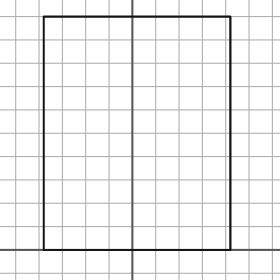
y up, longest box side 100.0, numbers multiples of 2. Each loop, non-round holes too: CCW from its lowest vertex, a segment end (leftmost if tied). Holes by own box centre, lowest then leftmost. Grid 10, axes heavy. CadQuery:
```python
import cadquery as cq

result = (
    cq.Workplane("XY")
    .moveTo(-38.0, 0.0)
    .lineTo(42.0, 0.0)
    .lineTo(42.0, 100.0)
    .lineTo(-38.0, 100.0)
    .close()
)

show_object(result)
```